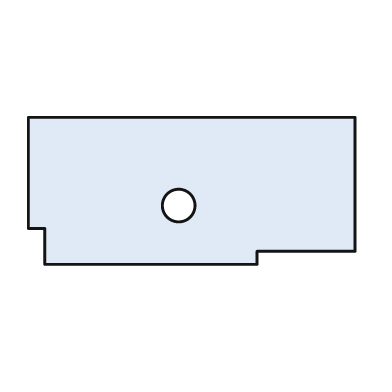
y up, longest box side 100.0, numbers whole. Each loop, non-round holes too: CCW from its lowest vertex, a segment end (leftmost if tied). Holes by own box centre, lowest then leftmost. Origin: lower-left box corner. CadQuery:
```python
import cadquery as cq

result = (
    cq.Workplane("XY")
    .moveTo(5.0, 0.0)
    .lineTo(70.0, 0.0)
    .lineTo(70.0, 4.0)
    .lineTo(100.0, 4.0)
    .lineTo(100.0, 45.0)
    .lineTo(0.0, 45.0)
    .lineTo(0.0, 11.0)
    .lineTo(5.0, 11.0)
    .close()
    .moveTo(46.0, 18.0)
    .circle(5.0)
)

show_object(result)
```